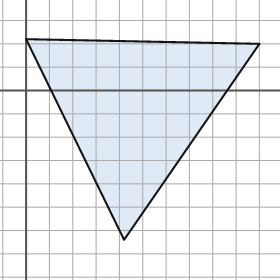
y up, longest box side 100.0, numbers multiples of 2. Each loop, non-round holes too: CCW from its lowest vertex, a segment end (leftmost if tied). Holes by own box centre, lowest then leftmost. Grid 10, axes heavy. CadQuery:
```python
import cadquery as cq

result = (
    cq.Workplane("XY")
    .moveTo(42.0, -64.0)
    .lineTo(100.0, 20.0)
    .lineTo(0.0, 22.0)
    .close()
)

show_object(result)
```